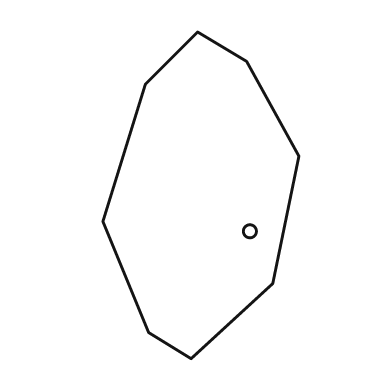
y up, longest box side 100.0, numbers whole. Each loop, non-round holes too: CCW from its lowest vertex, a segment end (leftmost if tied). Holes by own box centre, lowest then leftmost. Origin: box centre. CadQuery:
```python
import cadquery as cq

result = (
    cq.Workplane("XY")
    .moveTo(-3.0, -50.0)
    .lineTo(22.0, -27.0)
    .lineTo(30.0, 12.0)
    .lineTo(14.0, 41.0)
    .lineTo(-1.0, 50.0)
    .lineTo(-17.0, 34.0)
    .lineTo(-30.0, -8.0)
    .lineTo(-16.0, -42.0)
    .close()
    .moveTo(15.0, -11.0)
    .circle(2.0)
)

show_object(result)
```